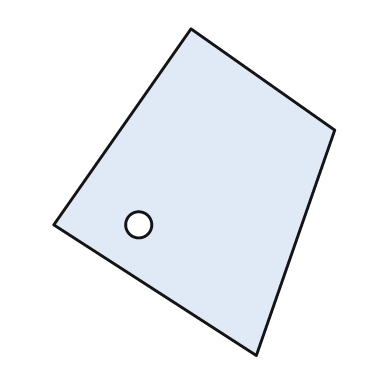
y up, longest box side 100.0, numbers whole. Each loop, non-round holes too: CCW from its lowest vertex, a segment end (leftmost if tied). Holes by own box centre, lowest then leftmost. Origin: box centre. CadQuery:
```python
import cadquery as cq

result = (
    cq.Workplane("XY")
    .moveTo(19.0, -50.0)
    .lineTo(43.0, 19.0)
    .lineTo(-1.0, 50.0)
    .lineTo(-43.0, -10.0)
    .close()
    .moveTo(-17.0, -10.0)
    .circle(4.0)
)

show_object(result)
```